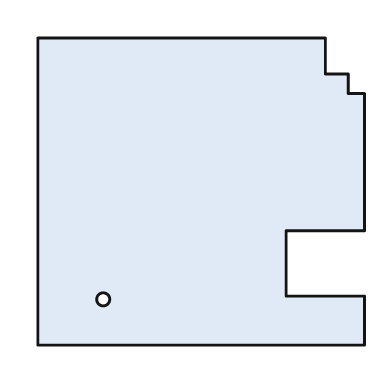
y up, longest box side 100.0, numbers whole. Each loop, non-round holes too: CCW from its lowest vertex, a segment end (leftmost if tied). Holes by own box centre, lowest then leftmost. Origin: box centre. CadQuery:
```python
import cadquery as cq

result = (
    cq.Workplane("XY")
    .moveTo(-50.0, -47.0)
    .lineTo(50.0, -47.0)
    .lineTo(50.0, -32.0)
    .lineTo(26.0, -32.0)
    .lineTo(26.0, -12.0)
    .lineTo(50.0, -12.0)
    .lineTo(50.0, 30.0)
    .lineTo(45.0, 30.0)
    .lineTo(45.0, 36.0)
    .lineTo(38.0, 36.0)
    .lineTo(38.0, 47.0)
    .lineTo(-50.0, 47.0)
    .close()
    .moveTo(-30.0, -33.0)
    .circle(2.0)
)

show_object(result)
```